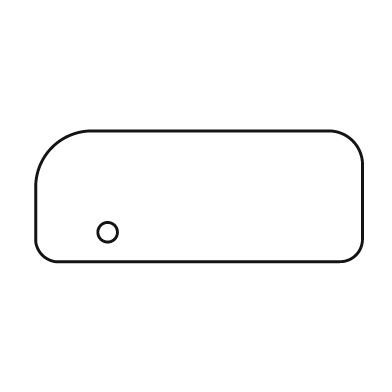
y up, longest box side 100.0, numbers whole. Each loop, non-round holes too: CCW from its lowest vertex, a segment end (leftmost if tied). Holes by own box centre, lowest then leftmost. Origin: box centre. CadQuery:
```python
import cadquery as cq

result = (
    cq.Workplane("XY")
    .moveTo(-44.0, -20.0)
    .lineTo(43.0, -20.0)
    .threePointArc((48.0, -18.0), (50.0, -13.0))
    .lineTo(50.0, 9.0)
    .threePointArc((47.0, 17.0), (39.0, 20.0))
    .lineTo(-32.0, 20.0)
    .threePointArc((-45.0, 15.0), (-50.0, 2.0))
    .lineTo(-50.0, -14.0)
    .threePointArc((-48.0, -18.0), (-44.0, -20.0))
    .close()
    .moveTo(-28.0, -11.0)
    .circle(3.0)
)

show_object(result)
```